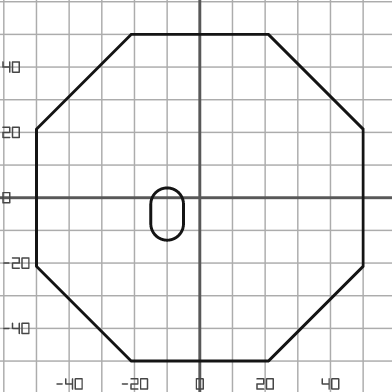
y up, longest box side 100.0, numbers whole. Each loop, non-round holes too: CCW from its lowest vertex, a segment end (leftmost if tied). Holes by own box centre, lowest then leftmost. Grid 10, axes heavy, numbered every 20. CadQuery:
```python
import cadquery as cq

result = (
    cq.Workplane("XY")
    .moveTo(-21.0, -50.0)
    .lineTo(21.0, -50.0)
    .lineTo(50.0, -21.0)
    .lineTo(50.0, 21.0)
    .lineTo(21.0, 50.0)
    .lineTo(-21.0, 50.0)
    .lineTo(-50.0, 21.0)
    .lineTo(-50.0, -21.0)
    .close()
    .moveTo(-15.0, -8.0)
    .threePointArc((-10.0, -13.0), (-5.0, -8.0))
    .lineTo(-5.0, -2.0)
    .threePointArc((-10.0, 3.0), (-15.0, -2.0))
    .close()
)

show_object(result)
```